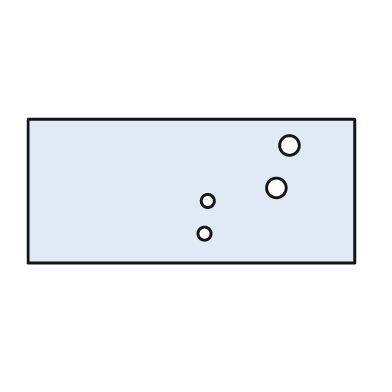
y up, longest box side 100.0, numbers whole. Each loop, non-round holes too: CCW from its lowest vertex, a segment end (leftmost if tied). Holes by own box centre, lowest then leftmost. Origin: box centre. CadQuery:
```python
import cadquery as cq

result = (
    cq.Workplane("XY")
    .moveTo(-50.0, -22.0)
    .lineTo(50.0, -22.0)
    .lineTo(50.0, 22.0)
    .lineTo(-50.0, 22.0)
    .close()
    .moveTo(4.0, -13.0)
    .circle(2.0)
    .moveTo(5.0, -3.0)
    .circle(2.0)
    .moveTo(26.0, 1.0)
    .circle(3.0)
    .moveTo(30.0, 14.0)
    .circle(3.0)
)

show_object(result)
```